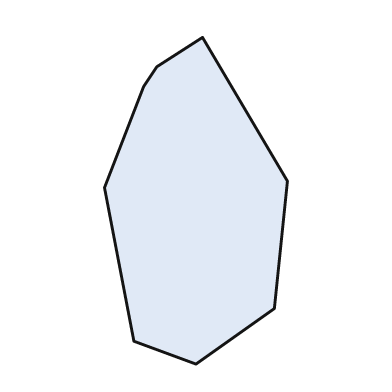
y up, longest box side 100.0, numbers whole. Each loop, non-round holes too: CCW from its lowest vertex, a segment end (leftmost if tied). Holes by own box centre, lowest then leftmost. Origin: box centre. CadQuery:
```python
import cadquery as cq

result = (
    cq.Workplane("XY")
    .moveTo(0.0, -50.0)
    .lineTo(24.0, -33.0)
    .lineTo(28.0, 6.0)
    .lineTo(2.0, 50.0)
    .lineTo(-12.0, 41.0)
    .lineTo(-16.0, 35.0)
    .lineTo(-28.0, 4.0)
    .lineTo(-19.0, -43.0)
    .close()
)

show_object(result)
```